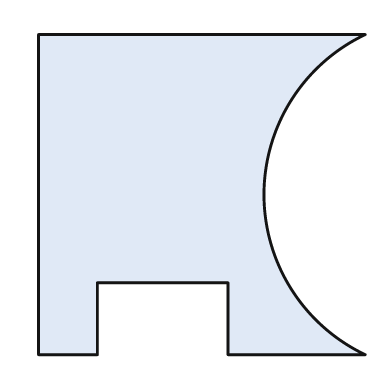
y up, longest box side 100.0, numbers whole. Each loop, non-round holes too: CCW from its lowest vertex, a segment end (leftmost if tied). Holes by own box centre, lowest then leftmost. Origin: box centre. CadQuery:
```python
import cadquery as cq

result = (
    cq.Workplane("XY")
    .moveTo(-50.0, -49.0)
    .lineTo(-32.0, -49.0)
    .lineTo(-32.0, -27.0)
    .lineTo(8.0, -27.0)
    .lineTo(8.0, -49.0)
    .lineTo(50.0, -49.0)
    .threePointArc((19.0, 0.0), (50.0, 49.0))
    .lineTo(-50.0, 49.0)
    .close()
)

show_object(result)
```